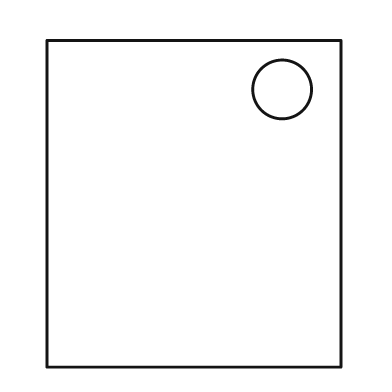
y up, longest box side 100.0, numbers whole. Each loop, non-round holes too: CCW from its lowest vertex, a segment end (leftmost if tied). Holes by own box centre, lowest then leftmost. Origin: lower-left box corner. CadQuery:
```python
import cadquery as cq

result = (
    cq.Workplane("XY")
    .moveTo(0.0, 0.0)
    .lineTo(90.0, 0.0)
    .lineTo(90.0, 100.0)
    .lineTo(0.0, 100.0)
    .close()
    .moveTo(72.0, 85.0)
    .circle(9.0)
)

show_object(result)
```